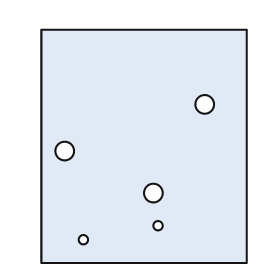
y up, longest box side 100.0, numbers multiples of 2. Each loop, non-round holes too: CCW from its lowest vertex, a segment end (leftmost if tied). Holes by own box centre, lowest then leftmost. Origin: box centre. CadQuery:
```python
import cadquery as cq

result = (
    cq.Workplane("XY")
    .moveTo(-44.0, -50.0)
    .lineTo(44.0, -50.0)
    .lineTo(44.0, 50.0)
    .lineTo(-44.0, 50.0)
    .close()
    .moveTo(-26.0, -40.0)
    .circle(2.0)
    .moveTo(6.0, -34.0)
    .circle(2.0)
    .moveTo(4.0, -20.0)
    .circle(4.0)
    .moveTo(-34.0, -2.0)
    .circle(4.0)
    .moveTo(26.0, 18.0)
    .circle(4.0)
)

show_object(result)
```